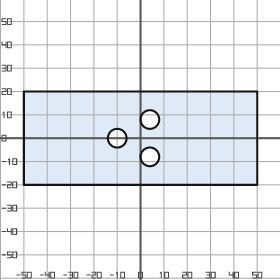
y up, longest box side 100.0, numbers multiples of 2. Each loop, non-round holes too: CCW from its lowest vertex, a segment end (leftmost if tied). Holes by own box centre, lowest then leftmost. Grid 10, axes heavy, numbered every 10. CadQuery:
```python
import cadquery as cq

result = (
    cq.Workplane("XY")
    .moveTo(-50.0, -20.0)
    .lineTo(50.0, -20.0)
    .lineTo(50.0, 20.0)
    .lineTo(-50.0, 20.0)
    .close()
    .moveTo(4.0, -8.0)
    .circle(4.0)
    .moveTo(-10.0, 0.0)
    .circle(4.0)
    .moveTo(4.0, 8.0)
    .circle(4.0)
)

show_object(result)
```